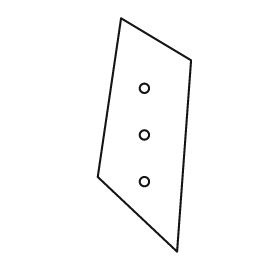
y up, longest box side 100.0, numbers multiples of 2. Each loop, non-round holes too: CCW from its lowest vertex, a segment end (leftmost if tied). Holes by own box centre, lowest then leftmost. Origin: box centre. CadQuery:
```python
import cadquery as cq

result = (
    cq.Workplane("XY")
    .moveTo(14.0, -50.0)
    .lineTo(20.0, 32.0)
    .lineTo(-10.0, 50.0)
    .lineTo(-20.0, -18.0)
    .close()
    .moveTo(0.0, -20.0)
    .circle(2.0)
    .moveTo(0.0, 0.0)
    .circle(2.0)
    .moveTo(0.0, 20.0)
    .circle(2.0)
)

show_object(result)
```